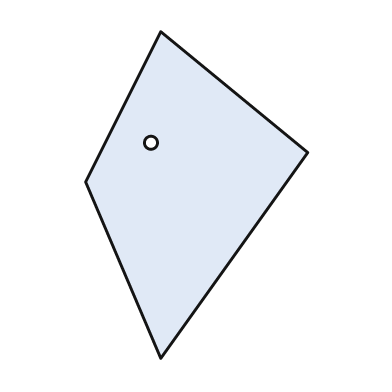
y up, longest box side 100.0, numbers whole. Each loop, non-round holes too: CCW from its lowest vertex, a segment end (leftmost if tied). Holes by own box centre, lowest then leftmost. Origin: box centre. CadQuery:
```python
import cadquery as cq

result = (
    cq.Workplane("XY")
    .moveTo(-11.0, -50.0)
    .lineTo(34.0, 13.0)
    .lineTo(-11.0, 50.0)
    .lineTo(-34.0, 4.0)
    .close()
    .moveTo(-14.0, 16.0)
    .circle(2.0)
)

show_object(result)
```